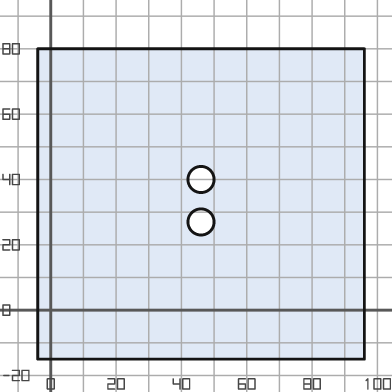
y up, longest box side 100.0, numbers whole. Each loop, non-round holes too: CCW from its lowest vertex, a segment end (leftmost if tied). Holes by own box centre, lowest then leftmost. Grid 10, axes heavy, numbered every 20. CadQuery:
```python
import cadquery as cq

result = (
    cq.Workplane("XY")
    .moveTo(-4.0, -15.0)
    .lineTo(96.0, -15.0)
    .lineTo(96.0, 80.0)
    .lineTo(-4.0, 80.0)
    .close()
    .moveTo(46.0, 27.0)
    .circle(4.0)
    .moveTo(46.0, 40.0)
    .circle(4.0)
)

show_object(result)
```